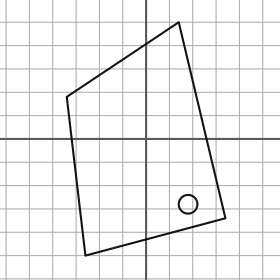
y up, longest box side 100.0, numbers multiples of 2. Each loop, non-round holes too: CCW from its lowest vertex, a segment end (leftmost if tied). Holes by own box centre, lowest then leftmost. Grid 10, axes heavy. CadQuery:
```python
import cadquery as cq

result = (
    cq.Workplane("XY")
    .moveTo(-26.0, -50.0)
    .lineTo(34.0, -34.0)
    .lineTo(14.0, 50.0)
    .lineTo(-34.0, 18.0)
    .close()
    .moveTo(18.0, -28.0)
    .circle(4.0)
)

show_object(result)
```